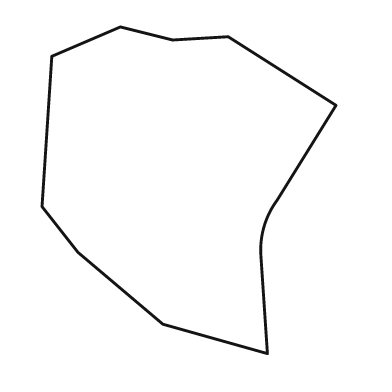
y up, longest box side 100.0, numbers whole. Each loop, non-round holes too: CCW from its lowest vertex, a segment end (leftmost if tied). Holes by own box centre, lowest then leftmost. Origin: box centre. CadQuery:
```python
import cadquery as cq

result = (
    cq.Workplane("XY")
    .moveTo(24.0, -50.0)
    .lineTo(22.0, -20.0)
    .threePointArc((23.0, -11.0), (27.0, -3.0))
    .lineTo(45.0, 26.0)
    .lineTo(12.0, 47.0)
    .lineTo(-5.0, 46.0)
    .lineTo(-21.0, 50.0)
    .lineTo(-42.0, 41.0)
    .lineTo(-45.0, -5.0)
    .lineTo(-34.0, -19.0)
    .lineTo(-8.0, -41.0)
    .close()
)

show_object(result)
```